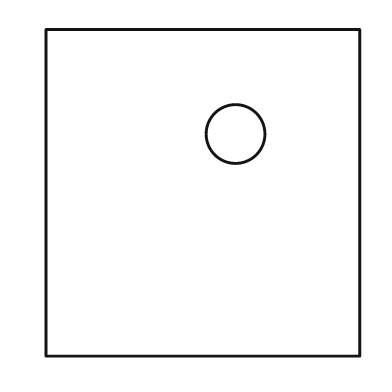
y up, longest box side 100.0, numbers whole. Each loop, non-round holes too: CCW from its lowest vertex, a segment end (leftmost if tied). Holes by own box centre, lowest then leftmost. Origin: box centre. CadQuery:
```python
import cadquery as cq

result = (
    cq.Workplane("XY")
    .moveTo(-48.0, -50.0)
    .lineTo(48.0, -50.0)
    .lineTo(48.0, 50.0)
    .lineTo(-48.0, 50.0)
    .close()
    .moveTo(10.0, 18.0)
    .circle(9.0)
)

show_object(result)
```